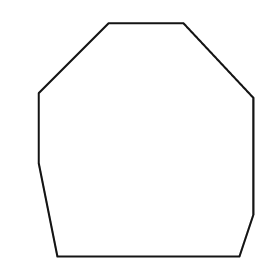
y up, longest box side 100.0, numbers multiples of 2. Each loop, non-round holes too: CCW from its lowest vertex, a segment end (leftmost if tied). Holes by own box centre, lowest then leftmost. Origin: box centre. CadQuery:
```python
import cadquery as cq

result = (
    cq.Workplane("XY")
    .moveTo(-38.0, -50.0)
    .lineTo(40.0, -50.0)
    .lineTo(46.0, -32.0)
    .lineTo(46.0, 18.0)
    .lineTo(16.0, 50.0)
    .lineTo(-16.0, 50.0)
    .lineTo(-46.0, 20.0)
    .lineTo(-46.0, -10.0)
    .close()
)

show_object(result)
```